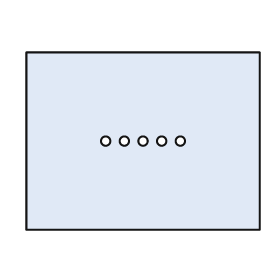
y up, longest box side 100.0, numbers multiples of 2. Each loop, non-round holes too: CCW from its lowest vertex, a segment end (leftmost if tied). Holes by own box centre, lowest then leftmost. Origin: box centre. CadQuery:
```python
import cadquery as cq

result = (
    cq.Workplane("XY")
    .moveTo(-50.0, -38.0)
    .lineTo(50.0, -38.0)
    .lineTo(50.0, 38.0)
    .lineTo(-50.0, 38.0)
    .close()
    .moveTo(-16.0, 0.0)
    .circle(2.0)
    .moveTo(-8.0, 0.0)
    .circle(2.0)
    .moveTo(0.0, 0.0)
    .circle(2.0)
    .moveTo(8.0, 0.0)
    .circle(2.0)
    .moveTo(16.0, 0.0)
    .circle(2.0)
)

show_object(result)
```